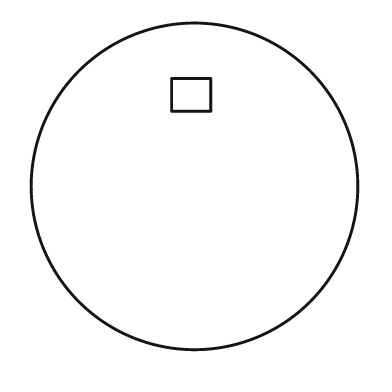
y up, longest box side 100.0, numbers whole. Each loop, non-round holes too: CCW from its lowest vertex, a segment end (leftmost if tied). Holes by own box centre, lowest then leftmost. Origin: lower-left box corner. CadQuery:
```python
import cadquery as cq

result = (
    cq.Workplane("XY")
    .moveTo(50.0, 50.0)
    .circle(50.0)
    .moveTo(43.0, 73.0)
    .lineTo(55.0, 73.0)
    .lineTo(55.0, 83.0)
    .lineTo(43.0, 83.0)
    .close()
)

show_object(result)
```